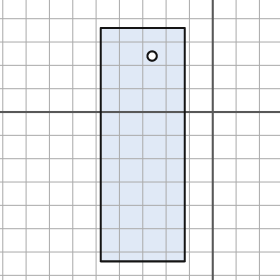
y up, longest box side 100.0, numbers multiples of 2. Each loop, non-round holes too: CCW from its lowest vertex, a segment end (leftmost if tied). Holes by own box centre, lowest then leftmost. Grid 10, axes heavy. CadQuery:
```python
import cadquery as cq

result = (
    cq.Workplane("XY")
    .moveTo(-48.0, -64.0)
    .lineTo(-12.0, -64.0)
    .lineTo(-12.0, 36.0)
    .lineTo(-48.0, 36.0)
    .close()
    .moveTo(-26.0, 24.0)
    .circle(2.0)
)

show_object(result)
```